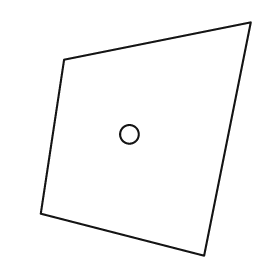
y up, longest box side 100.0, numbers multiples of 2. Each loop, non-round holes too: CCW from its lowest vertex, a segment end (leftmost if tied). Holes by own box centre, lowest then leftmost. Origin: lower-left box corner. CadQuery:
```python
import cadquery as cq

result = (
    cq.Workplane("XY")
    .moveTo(70.0, 0.0)
    .lineTo(90.0, 100.0)
    .lineTo(10.0, 84.0)
    .lineTo(0.0, 18.0)
    .close()
    .moveTo(38.0, 52.0)
    .circle(4.0)
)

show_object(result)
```